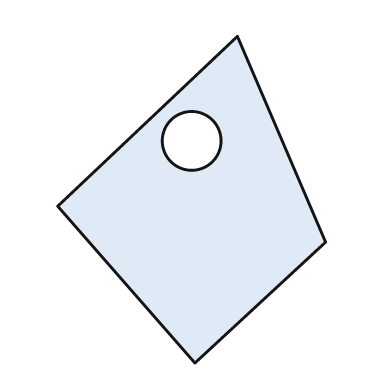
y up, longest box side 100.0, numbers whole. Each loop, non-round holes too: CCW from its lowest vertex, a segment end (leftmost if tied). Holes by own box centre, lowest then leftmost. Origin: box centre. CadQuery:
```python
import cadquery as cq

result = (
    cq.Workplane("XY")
    .moveTo(1.0, -50.0)
    .lineTo(41.0, -13.0)
    .lineTo(14.0, 50.0)
    .lineTo(-41.0, -2.0)
    .close()
    .moveTo(0.0, 18.0)
    .circle(9.0)
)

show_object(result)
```